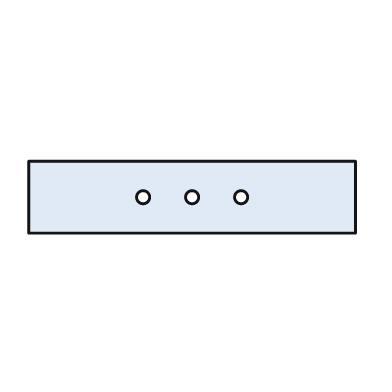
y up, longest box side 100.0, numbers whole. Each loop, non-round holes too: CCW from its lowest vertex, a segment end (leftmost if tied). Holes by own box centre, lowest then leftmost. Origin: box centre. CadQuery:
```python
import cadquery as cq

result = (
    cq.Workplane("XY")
    .moveTo(-50.0, -11.0)
    .lineTo(50.0, -11.0)
    .lineTo(50.0, 11.0)
    .lineTo(-50.0, 11.0)
    .close()
    .moveTo(-15.0, 0.0)
    .circle(2.0)
    .moveTo(0.0, 0.0)
    .circle(2.0)
    .moveTo(15.0, 0.0)
    .circle(2.0)
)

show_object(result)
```